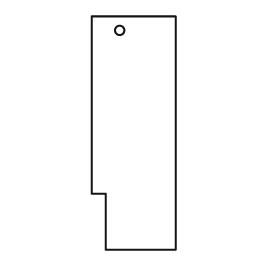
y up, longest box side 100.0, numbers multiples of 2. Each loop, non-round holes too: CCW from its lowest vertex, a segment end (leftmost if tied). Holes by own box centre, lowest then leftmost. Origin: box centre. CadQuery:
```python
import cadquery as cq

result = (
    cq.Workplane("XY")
    .moveTo(-12.0, -50.0)
    .lineTo(18.0, -50.0)
    .lineTo(18.0, 50.0)
    .lineTo(-18.0, 50.0)
    .lineTo(-18.0, -26.0)
    .lineTo(-12.0, -26.0)
    .close()
    .moveTo(-6.0, 44.0)
    .circle(2.0)
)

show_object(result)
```